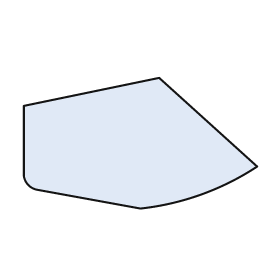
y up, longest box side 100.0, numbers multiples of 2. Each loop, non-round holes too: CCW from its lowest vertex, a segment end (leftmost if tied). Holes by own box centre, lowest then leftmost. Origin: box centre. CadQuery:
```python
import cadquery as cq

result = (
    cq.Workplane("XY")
    .moveTo(0.0, -28.0)
    .threePointArc((26.0, -22.0), (50.0, -10.0))
    .lineTo(8.0, 28.0)
    .lineTo(-50.0, 16.0)
    .lineTo(-50.0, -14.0)
    .threePointArc((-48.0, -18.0), (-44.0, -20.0))
    .close()
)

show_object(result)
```